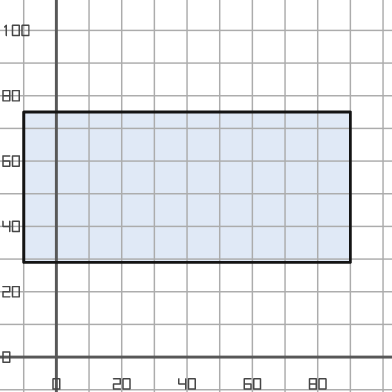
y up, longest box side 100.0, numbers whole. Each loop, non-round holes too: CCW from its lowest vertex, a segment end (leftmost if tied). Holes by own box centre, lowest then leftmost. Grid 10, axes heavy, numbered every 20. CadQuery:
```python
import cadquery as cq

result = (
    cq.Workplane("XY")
    .moveTo(-10.0, 29.0)
    .lineTo(90.0, 29.0)
    .lineTo(90.0, 75.0)
    .lineTo(-10.0, 75.0)
    .close()
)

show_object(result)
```